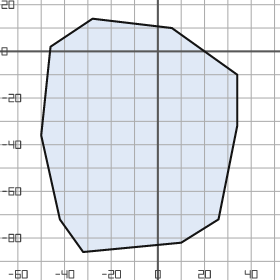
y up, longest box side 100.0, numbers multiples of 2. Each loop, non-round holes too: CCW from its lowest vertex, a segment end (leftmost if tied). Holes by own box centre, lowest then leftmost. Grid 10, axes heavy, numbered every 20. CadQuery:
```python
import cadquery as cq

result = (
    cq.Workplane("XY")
    .moveTo(-32.0, -86.0)
    .lineTo(10.0, -82.0)
    .lineTo(26.0, -72.0)
    .lineTo(34.0, -32.0)
    .lineTo(34.0, -10.0)
    .lineTo(6.0, 10.0)
    .lineTo(-28.0, 14.0)
    .lineTo(-46.0, 2.0)
    .lineTo(-50.0, -36.0)
    .lineTo(-42.0, -72.0)
    .close()
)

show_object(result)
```